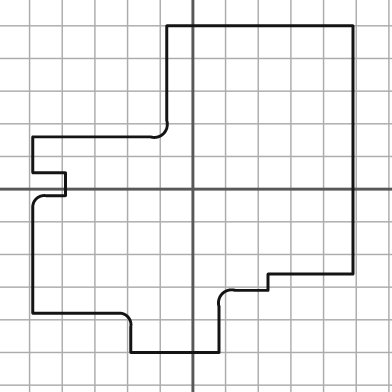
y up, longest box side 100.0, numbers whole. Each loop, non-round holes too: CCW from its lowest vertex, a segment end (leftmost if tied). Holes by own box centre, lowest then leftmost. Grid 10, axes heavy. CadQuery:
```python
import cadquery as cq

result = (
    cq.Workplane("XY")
    .moveTo(-19.0, -50.0)
    .lineTo(8.0, -50.0)
    .lineTo(8.0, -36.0)
    .threePointArc((9.0, -32.0), (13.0, -31.0))
    .lineTo(23.0, -31.0)
    .lineTo(23.0, -26.0)
    .lineTo(49.0, -26.0)
    .lineTo(49.0, 50.0)
    .lineTo(-8.0, 50.0)
    .lineTo(-8.0, 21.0)
    .threePointArc((-9.0, 17.0), (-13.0, 16.0))
    .lineTo(-49.0, 16.0)
    .lineTo(-49.0, 5.0)
    .lineTo(-39.0, 5.0)
    .lineTo(-39.0, -2.0)
    .lineTo(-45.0, -2.0)
    .threePointArc((-48.0, -3.0), (-49.0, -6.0))
    .lineTo(-49.0, -38.0)
    .lineTo(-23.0, -38.0)
    .threePointArc((-20.0, -39.0), (-19.0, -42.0))
    .close()
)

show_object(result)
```